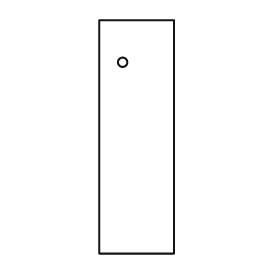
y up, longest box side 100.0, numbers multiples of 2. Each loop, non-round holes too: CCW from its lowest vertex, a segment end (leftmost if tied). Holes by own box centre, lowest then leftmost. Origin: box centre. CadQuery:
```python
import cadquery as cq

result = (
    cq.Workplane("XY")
    .moveTo(-16.0, -50.0)
    .lineTo(16.0, -50.0)
    .lineTo(16.0, 50.0)
    .lineTo(-16.0, 50.0)
    .close()
    .moveTo(-6.0, 32.0)
    .circle(2.0)
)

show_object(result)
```